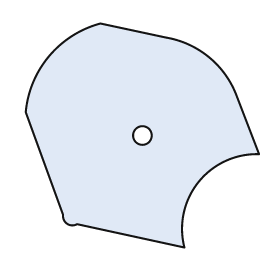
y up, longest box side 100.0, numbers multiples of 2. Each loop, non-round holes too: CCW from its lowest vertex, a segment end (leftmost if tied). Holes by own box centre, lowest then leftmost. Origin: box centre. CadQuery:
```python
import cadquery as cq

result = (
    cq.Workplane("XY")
    .moveTo(18.0, -48.0)
    .threePointArc((24.0, -20.0), (50.0, -8.0))
    .lineTo(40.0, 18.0)
    .threePointArc((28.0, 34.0), (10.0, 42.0))
    .lineTo(-18.0, 48.0)
    .threePointArc((-40.0, 34.0), (-50.0, 10.0))
    .lineTo(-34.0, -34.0)
    .threePointArc((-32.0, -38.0), (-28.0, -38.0))
    .close()
    .moveTo(0.0, 0.0)
    .circle(4.0)
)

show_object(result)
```